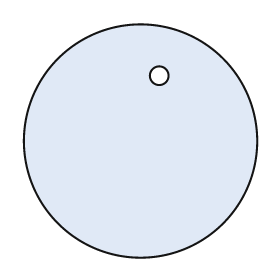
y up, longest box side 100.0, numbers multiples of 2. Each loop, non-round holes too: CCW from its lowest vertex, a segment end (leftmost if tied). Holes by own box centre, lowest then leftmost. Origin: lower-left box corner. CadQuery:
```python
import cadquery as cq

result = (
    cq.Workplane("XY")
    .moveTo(50.0, 50.0)
    .circle(50.0)
    .moveTo(58.0, 78.0)
    .circle(4.0)
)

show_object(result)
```